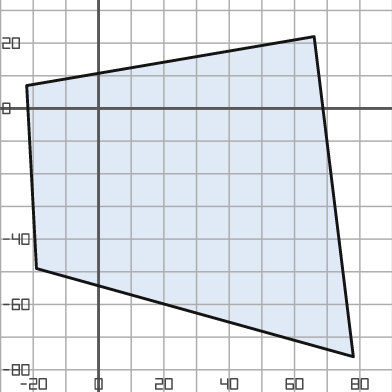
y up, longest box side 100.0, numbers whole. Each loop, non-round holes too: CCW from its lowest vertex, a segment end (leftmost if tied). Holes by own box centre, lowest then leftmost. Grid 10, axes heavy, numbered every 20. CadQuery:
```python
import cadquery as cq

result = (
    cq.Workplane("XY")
    .moveTo(78.0, -76.0)
    .lineTo(66.0, 22.0)
    .lineTo(-22.0, 7.0)
    .lineTo(-19.0, -49.0)
    .close()
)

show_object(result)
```